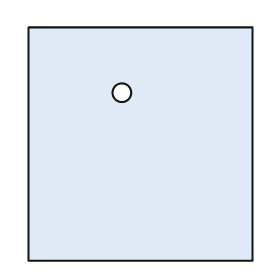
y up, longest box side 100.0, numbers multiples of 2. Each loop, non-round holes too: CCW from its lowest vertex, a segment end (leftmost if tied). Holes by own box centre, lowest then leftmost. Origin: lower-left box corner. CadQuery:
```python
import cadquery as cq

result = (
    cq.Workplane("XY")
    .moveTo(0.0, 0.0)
    .lineTo(96.0, 0.0)
    .lineTo(96.0, 100.0)
    .lineTo(0.0, 100.0)
    .close()
    .moveTo(40.0, 72.0)
    .circle(4.0)
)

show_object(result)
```